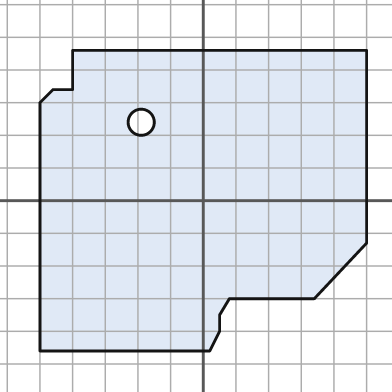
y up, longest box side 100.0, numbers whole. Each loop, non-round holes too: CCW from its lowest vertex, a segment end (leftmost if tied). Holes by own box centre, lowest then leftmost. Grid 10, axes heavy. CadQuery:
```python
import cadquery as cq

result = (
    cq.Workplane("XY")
    .moveTo(-50.0, -46.0)
    .lineTo(2.0, -46.0)
    .lineTo(5.0, -40.0)
    .lineTo(5.0, -35.0)
    .lineTo(8.0, -30.0)
    .lineTo(34.0, -30.0)
    .lineTo(50.0, -13.0)
    .lineTo(50.0, 46.0)
    .lineTo(-40.0, 46.0)
    .lineTo(-40.0, 34.0)
    .lineTo(-46.0, 34.0)
    .lineTo(-50.0, 30.0)
    .close()
    .moveTo(-19.0, 24.0)
    .circle(4.0)
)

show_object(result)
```